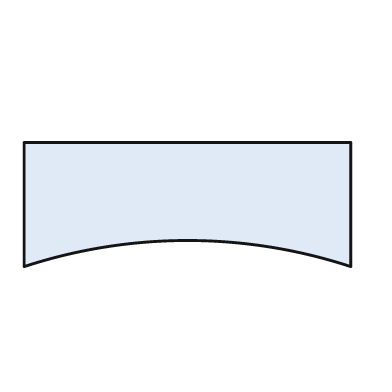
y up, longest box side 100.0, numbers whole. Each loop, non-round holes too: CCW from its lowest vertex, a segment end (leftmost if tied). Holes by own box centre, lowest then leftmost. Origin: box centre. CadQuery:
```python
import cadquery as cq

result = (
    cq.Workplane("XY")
    .moveTo(-50.0, -19.0)
    .threePointArc((0.0, -11.0), (50.0, -19.0))
    .lineTo(50.0, 19.0)
    .lineTo(-50.0, 19.0)
    .close()
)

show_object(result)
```